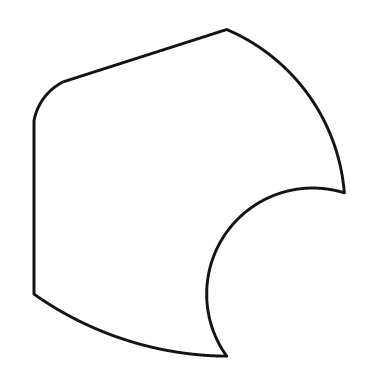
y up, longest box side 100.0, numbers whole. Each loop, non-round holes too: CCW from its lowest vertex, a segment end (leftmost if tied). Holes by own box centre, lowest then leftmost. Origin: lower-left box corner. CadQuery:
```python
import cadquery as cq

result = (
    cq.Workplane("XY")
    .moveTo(59.0, 0.0)
    .threePointArc((59.0, 38.0), (95.0, 50.0))
    .threePointArc((84.0, 80.0), (59.0, 100.0))
    .lineTo(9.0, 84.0)
    .threePointArc((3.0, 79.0), (0.0, 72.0))
    .lineTo(0.0, 19.0)
    .threePointArc((28.0, 5.0), (59.0, 0.0))
    .close()
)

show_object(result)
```